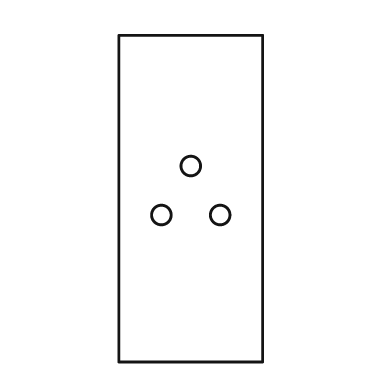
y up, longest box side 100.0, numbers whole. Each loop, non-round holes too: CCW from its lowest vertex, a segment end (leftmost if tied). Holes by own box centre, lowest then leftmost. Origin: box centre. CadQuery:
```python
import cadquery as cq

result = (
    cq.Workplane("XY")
    .moveTo(-22.0, -50.0)
    .lineTo(22.0, -50.0)
    .lineTo(22.0, 50.0)
    .lineTo(-22.0, 50.0)
    .close()
    .moveTo(-9.0, -5.0)
    .circle(3.0)
    .moveTo(9.0, -5.0)
    .circle(3.0)
    .moveTo(0.0, 10.0)
    .circle(3.0)
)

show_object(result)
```